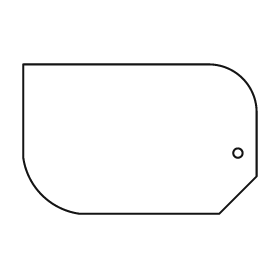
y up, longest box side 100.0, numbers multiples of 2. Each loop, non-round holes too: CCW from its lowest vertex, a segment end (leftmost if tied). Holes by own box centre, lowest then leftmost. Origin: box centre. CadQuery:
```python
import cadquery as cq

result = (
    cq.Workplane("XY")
    .moveTo(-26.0, -32.0)
    .lineTo(34.0, -32.0)
    .lineTo(50.0, -16.0)
    .lineTo(50.0, 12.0)
    .threePointArc((44.0, 26.0), (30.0, 32.0))
    .lineTo(-50.0, 32.0)
    .lineTo(-50.0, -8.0)
    .threePointArc((-42.0, -24.0), (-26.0, -32.0))
    .close()
    .moveTo(42.0, -6.0)
    .circle(2.0)
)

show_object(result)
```